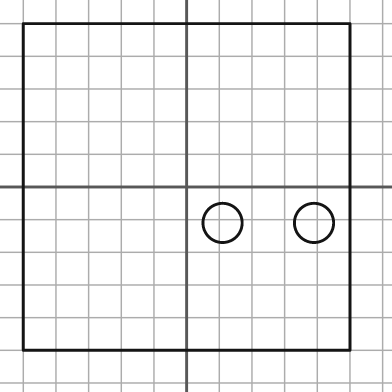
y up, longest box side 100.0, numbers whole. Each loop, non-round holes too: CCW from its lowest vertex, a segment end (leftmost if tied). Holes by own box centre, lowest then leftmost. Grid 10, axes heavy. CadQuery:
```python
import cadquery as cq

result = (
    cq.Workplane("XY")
    .moveTo(-50.0, -50.0)
    .lineTo(50.0, -50.0)
    .lineTo(50.0, 50.0)
    .lineTo(-50.0, 50.0)
    .close()
    .moveTo(11.0, -11.0)
    .circle(6.0)
    .moveTo(39.0, -11.0)
    .circle(6.0)
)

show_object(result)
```